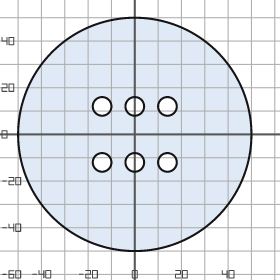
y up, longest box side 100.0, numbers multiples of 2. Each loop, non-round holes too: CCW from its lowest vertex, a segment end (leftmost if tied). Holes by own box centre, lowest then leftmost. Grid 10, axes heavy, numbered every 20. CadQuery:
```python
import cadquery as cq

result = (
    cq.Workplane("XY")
    .moveTo(0.0, 0.0)
    .circle(50.0)
    .moveTo(-14.0, -12.0)
    .circle(4.0)
    .moveTo(0.0, -12.0)
    .circle(4.0)
    .moveTo(14.0, -12.0)
    .circle(4.0)
    .moveTo(-14.0, 12.0)
    .circle(4.0)
    .moveTo(0.0, 12.0)
    .circle(4.0)
    .moveTo(14.0, 12.0)
    .circle(4.0)
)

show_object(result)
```